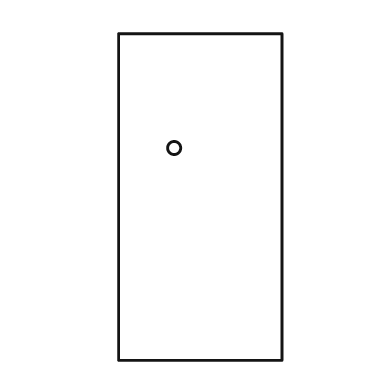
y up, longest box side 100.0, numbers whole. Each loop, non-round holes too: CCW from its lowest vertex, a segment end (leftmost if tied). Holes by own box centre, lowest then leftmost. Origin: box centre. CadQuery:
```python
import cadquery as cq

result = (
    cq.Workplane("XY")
    .moveTo(-25.0, -50.0)
    .lineTo(25.0, -50.0)
    .lineTo(25.0, 50.0)
    .lineTo(-25.0, 50.0)
    .close()
    .moveTo(-8.0, 15.0)
    .circle(2.0)
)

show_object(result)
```